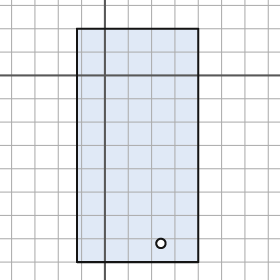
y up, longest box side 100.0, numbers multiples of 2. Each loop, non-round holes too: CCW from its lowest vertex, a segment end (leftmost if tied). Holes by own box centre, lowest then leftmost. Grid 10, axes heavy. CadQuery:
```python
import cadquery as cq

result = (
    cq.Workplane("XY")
    .moveTo(-12.0, -80.0)
    .lineTo(40.0, -80.0)
    .lineTo(40.0, 20.0)
    .lineTo(-12.0, 20.0)
    .close()
    .moveTo(24.0, -72.0)
    .circle(2.0)
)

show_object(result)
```